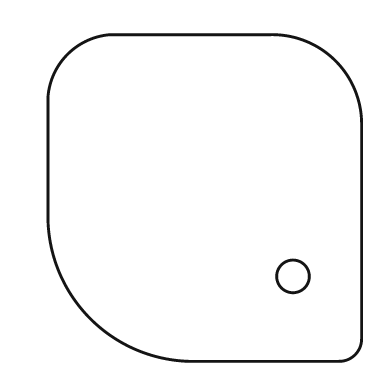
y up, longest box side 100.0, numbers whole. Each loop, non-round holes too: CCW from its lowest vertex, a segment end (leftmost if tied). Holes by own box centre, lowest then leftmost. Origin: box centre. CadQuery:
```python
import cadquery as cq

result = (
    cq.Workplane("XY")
    .moveTo(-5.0, -50.0)
    .lineTo(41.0, -50.0)
    .threePointArc((46.0, -48.0), (48.0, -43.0))
    .lineTo(48.0, 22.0)
    .threePointArc((40.0, 42.0), (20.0, 50.0))
    .lineTo(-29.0, 50.0)
    .threePointArc((-42.0, 44.0), (-48.0, 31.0))
    .lineTo(-48.0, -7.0)
    .threePointArc((-35.0, -37.0), (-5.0, -50.0))
    .close()
    .moveTo(27.0, -24.0)
    .circle(5.0)
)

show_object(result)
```